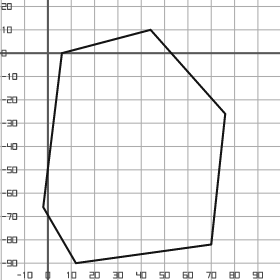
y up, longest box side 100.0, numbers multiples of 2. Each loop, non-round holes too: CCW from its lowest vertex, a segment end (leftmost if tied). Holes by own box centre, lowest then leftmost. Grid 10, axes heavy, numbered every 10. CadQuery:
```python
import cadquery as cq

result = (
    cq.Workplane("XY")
    .moveTo(12.0, -90.0)
    .lineTo(70.0, -82.0)
    .lineTo(76.0, -26.0)
    .lineTo(44.0, 10.0)
    .lineTo(6.0, 0.0)
    .lineTo(-2.0, -66.0)
    .close()
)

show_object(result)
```